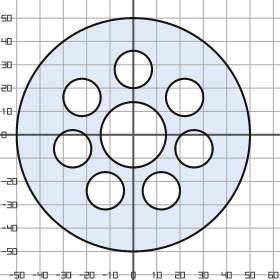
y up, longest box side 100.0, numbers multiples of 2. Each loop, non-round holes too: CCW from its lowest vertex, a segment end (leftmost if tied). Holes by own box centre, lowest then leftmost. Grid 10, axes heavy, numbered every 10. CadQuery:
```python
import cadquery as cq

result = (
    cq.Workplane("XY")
    .moveTo(0.0, 0.0)
    .circle(50.0)
    .moveTo(-12.0, -24.0)
    .circle(8.0)
    .moveTo(12.0, -24.0)
    .circle(8.0)
    .moveTo(-26.0, -6.0)
    .circle(8.0)
    .moveTo(26.0, -6.0)
    .circle(8.0)
    .moveTo(0.0, 0.0)
    .circle(14.0)
    .moveTo(-22.0, 16.0)
    .circle(8.0)
    .moveTo(22.0, 16.0)
    .circle(8.0)
    .moveTo(0.0, 28.0)
    .circle(8.0)
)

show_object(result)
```